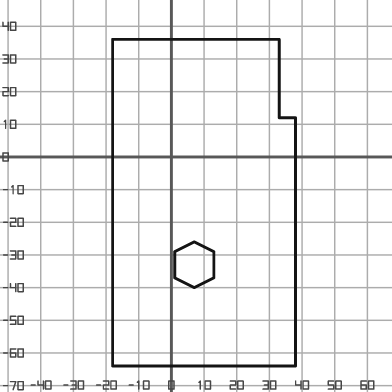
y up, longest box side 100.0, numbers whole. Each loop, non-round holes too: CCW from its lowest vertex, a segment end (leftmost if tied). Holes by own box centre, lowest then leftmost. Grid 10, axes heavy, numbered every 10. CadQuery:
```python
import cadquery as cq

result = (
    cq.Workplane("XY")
    .moveTo(-18.0, -64.0)
    .lineTo(38.0, -64.0)
    .lineTo(38.0, 12.0)
    .lineTo(33.0, 12.0)
    .lineTo(33.0, 36.0)
    .lineTo(-18.0, 36.0)
    .close()
    .moveTo(7.0, -40.0)
    .lineTo(13.0, -37.0)
    .lineTo(13.0, -29.0)
    .lineTo(7.0, -26.0)
    .lineTo(1.0, -29.0)
    .lineTo(1.0, -37.0)
    .close()
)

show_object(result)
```